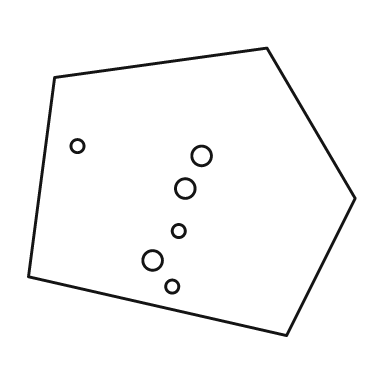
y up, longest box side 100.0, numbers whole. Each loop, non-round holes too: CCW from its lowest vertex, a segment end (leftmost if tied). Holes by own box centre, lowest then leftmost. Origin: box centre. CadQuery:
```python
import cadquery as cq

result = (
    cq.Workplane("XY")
    .moveTo(29.0, -44.0)
    .lineTo(50.0, -2.0)
    .lineTo(23.0, 44.0)
    .lineTo(-42.0, 35.0)
    .lineTo(-50.0, -26.0)
    .close()
    .moveTo(-6.0, -29.0)
    .circle(2.0)
    .moveTo(-12.0, -21.0)
    .circle(3.0)
    .moveTo(-4.0, -12.0)
    .circle(2.0)
    .moveTo(-2.0, 1.0)
    .circle(3.0)
    .moveTo(3.0, 11.0)
    .circle(3.0)
    .moveTo(-35.0, 14.0)
    .circle(2.0)
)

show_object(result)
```